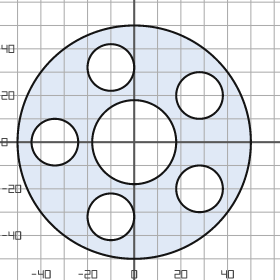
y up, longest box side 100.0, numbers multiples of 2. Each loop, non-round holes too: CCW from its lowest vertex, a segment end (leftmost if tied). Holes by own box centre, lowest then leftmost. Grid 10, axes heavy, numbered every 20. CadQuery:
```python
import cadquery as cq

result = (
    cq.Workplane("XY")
    .moveTo(0.0, 0.0)
    .circle(50.0)
    .moveTo(-10.0, -32.0)
    .circle(10.0)
    .moveTo(28.0, -20.0)
    .circle(10.0)
    .moveTo(-34.0, 0.0)
    .circle(10.0)
    .moveTo(0.0, 0.0)
    .circle(18.0)
    .moveTo(28.0, 20.0)
    .circle(10.0)
    .moveTo(-10.0, 32.0)
    .circle(10.0)
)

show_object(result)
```